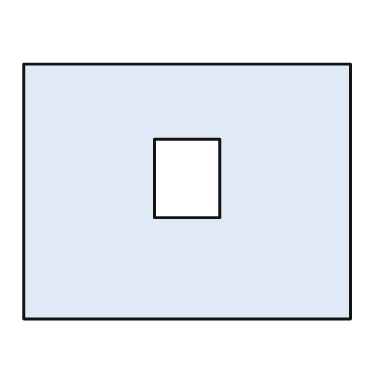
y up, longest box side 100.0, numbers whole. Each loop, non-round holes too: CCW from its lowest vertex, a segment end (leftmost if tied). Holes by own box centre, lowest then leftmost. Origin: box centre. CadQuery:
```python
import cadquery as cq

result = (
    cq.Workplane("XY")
    .moveTo(-50.0, -39.0)
    .lineTo(50.0, -39.0)
    .lineTo(50.0, 39.0)
    .lineTo(-50.0, 39.0)
    .close()
    .moveTo(-10.0, -8.0)
    .lineTo(10.0, -8.0)
    .lineTo(10.0, 16.0)
    .lineTo(-10.0, 16.0)
    .close()
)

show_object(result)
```